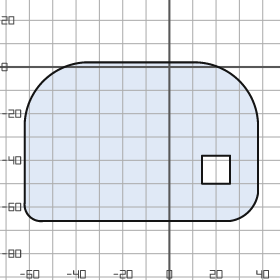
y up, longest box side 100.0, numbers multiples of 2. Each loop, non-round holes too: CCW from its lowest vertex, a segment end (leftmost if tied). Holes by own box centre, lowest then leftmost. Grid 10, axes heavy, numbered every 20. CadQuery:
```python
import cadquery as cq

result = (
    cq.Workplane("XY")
    .moveTo(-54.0, -66.0)
    .lineTo(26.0, -66.0)
    .threePointArc((34.0, -62.0), (38.0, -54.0))
    .lineTo(38.0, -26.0)
    .threePointArc((30.0, -6.0), (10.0, 2.0))
    .lineTo(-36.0, 2.0)
    .threePointArc((-54.0, -6.0), (-62.0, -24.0))
    .lineTo(-62.0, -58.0)
    .threePointArc((-60.0, -64.0), (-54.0, -66.0))
    .close()
    .moveTo(14.0, -50.0)
    .lineTo(26.0, -50.0)
    .lineTo(26.0, -38.0)
    .lineTo(14.0, -38.0)
    .close()
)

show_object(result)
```